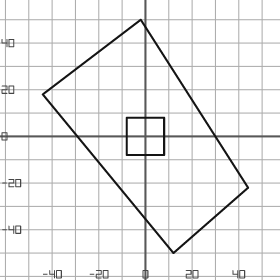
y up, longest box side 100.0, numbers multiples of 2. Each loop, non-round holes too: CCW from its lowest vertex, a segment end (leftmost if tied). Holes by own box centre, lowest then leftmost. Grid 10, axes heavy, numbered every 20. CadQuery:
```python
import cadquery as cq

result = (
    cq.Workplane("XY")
    .moveTo(12.0, -50.0)
    .lineTo(44.0, -22.0)
    .lineTo(-2.0, 50.0)
    .lineTo(-44.0, 18.0)
    .close()
    .moveTo(-8.0, -8.0)
    .lineTo(8.0, -8.0)
    .lineTo(8.0, 8.0)
    .lineTo(-8.0, 8.0)
    .close()
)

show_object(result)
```